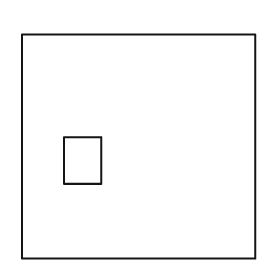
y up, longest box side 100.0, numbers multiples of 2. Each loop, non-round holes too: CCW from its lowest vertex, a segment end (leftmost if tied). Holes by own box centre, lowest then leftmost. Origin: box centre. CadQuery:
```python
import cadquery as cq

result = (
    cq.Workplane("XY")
    .moveTo(-50.0, -48.0)
    .lineTo(50.0, -48.0)
    .lineTo(50.0, 48.0)
    .lineTo(-50.0, 48.0)
    .close()
    .moveTo(-32.0, -16.0)
    .lineTo(-16.0, -16.0)
    .lineTo(-16.0, 4.0)
    .lineTo(-32.0, 4.0)
    .close()
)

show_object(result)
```